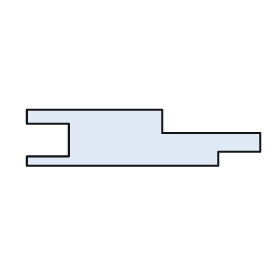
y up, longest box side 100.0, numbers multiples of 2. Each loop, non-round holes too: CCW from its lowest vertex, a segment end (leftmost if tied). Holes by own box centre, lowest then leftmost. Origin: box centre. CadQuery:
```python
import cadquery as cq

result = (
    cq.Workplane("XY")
    .moveTo(-50.0, -12.0)
    .lineTo(32.0, -12.0)
    .lineTo(32.0, -6.0)
    .lineTo(50.0, -6.0)
    .lineTo(50.0, 2.0)
    .lineTo(8.0, 2.0)
    .lineTo(8.0, 12.0)
    .lineTo(-50.0, 12.0)
    .lineTo(-50.0, 6.0)
    .lineTo(-32.0, 6.0)
    .lineTo(-32.0, -8.0)
    .lineTo(-50.0, -8.0)
    .close()
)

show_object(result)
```